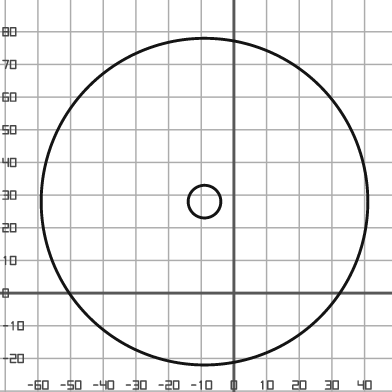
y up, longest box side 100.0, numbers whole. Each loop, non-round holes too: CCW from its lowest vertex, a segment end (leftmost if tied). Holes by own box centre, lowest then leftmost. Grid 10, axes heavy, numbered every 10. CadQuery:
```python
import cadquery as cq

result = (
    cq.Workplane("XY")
    .moveTo(-9.0, 28.0)
    .circle(50.0)
    .moveTo(-9.0, 28.0)
    .circle(5.0)
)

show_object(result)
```